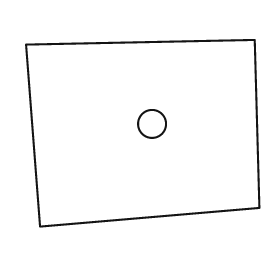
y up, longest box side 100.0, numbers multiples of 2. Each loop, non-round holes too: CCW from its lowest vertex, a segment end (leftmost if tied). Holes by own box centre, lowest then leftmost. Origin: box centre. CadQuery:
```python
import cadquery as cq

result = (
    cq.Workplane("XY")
    .moveTo(-44.0, -40.0)
    .lineTo(50.0, -32.0)
    .lineTo(48.0, 40.0)
    .lineTo(-50.0, 38.0)
    .close()
    .moveTo(4.0, 4.0)
    .circle(6.0)
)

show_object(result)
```